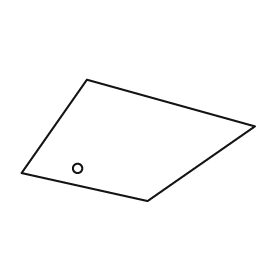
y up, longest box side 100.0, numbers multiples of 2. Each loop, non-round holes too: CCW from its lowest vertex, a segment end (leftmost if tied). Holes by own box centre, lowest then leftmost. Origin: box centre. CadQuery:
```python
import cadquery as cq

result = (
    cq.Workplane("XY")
    .moveTo(4.0, -26.0)
    .lineTo(50.0, 6.0)
    .lineTo(-22.0, 26.0)
    .lineTo(-50.0, -14.0)
    .close()
    .moveTo(-26.0, -12.0)
    .circle(2.0)
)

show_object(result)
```